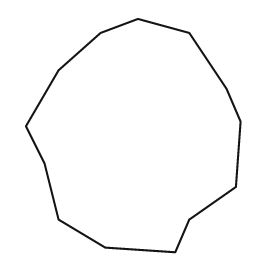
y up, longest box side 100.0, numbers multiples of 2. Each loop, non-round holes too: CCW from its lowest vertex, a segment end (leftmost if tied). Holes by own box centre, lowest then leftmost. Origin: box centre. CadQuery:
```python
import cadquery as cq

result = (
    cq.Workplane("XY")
    .moveTo(18.0, -50.0)
    .lineTo(24.0, -36.0)
    .lineTo(44.0, -22.0)
    .lineTo(46.0, 6.0)
    .lineTo(40.0, 20.0)
    .lineTo(24.0, 44.0)
    .lineTo(2.0, 50.0)
    .lineTo(-14.0, 44.0)
    .lineTo(-32.0, 28.0)
    .lineTo(-46.0, 4.0)
    .lineTo(-38.0, -12.0)
    .lineTo(-32.0, -36.0)
    .lineTo(-12.0, -48.0)
    .close()
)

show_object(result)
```